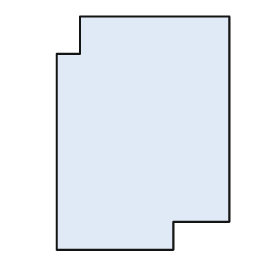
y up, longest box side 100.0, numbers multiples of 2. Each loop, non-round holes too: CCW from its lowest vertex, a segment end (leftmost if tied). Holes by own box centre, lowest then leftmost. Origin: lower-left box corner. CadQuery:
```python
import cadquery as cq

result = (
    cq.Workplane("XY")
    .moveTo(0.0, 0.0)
    .lineTo(50.0, 0.0)
    .lineTo(50.0, 12.0)
    .lineTo(74.0, 12.0)
    .lineTo(74.0, 100.0)
    .lineTo(10.0, 100.0)
    .lineTo(10.0, 84.0)
    .lineTo(0.0, 84.0)
    .close()
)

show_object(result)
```